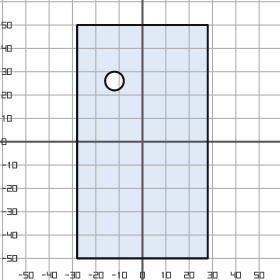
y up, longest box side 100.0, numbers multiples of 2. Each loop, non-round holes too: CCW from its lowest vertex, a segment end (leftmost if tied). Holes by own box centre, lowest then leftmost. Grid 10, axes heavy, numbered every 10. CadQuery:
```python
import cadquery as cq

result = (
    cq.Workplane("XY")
    .moveTo(-28.0, -50.0)
    .lineTo(28.0, -50.0)
    .lineTo(28.0, 50.0)
    .lineTo(-28.0, 50.0)
    .close()
    .moveTo(-12.0, 26.0)
    .circle(4.0)
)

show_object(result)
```